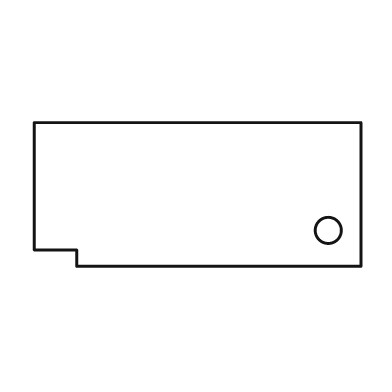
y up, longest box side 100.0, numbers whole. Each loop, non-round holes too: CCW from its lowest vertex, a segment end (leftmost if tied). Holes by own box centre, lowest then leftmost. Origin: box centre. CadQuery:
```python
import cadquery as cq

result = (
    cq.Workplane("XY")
    .moveTo(-37.0, -22.0)
    .lineTo(50.0, -22.0)
    .lineTo(50.0, 22.0)
    .lineTo(-50.0, 22.0)
    .lineTo(-50.0, -17.0)
    .lineTo(-37.0, -17.0)
    .close()
    .moveTo(40.0, -11.0)
    .circle(4.0)
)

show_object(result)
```